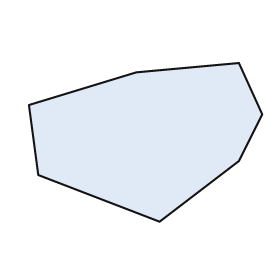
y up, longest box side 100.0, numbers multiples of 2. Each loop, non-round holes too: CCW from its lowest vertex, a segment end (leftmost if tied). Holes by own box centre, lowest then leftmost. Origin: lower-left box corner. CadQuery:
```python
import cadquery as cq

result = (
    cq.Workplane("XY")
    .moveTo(56.0, 0.0)
    .lineTo(90.0, 26.0)
    .lineTo(100.0, 46.0)
    .lineTo(90.0, 68.0)
    .lineTo(46.0, 64.0)
    .lineTo(0.0, 50.0)
    .lineTo(4.0, 20.0)
    .close()
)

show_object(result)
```